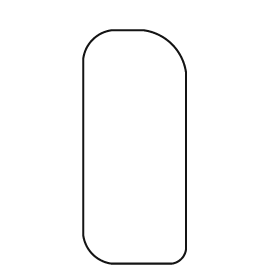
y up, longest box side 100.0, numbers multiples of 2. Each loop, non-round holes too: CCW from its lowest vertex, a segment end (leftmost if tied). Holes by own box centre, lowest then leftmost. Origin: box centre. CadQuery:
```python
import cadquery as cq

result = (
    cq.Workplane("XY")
    .moveTo(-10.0, -50.0)
    .lineTo(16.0, -50.0)
    .threePointArc((20.0, -48.0), (22.0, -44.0))
    .lineTo(22.0, 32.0)
    .threePointArc((16.0, 44.0), (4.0, 50.0))
    .lineTo(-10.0, 50.0)
    .threePointArc((-18.0, 46.0), (-22.0, 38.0))
    .lineTo(-22.0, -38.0)
    .threePointArc((-18.0, -46.0), (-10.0, -50.0))
    .close()
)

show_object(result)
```